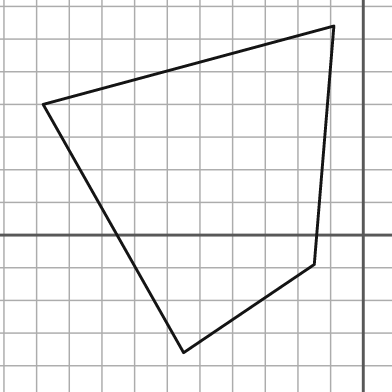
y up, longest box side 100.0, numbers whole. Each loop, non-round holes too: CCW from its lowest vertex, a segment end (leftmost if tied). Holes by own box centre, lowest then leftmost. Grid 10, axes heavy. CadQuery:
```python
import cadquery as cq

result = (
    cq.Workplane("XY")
    .moveTo(-55.0, -36.0)
    .lineTo(-15.0, -9.0)
    .lineTo(-9.0, 64.0)
    .lineTo(-98.0, 40.0)
    .close()
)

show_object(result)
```